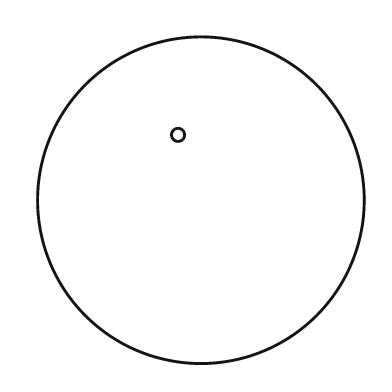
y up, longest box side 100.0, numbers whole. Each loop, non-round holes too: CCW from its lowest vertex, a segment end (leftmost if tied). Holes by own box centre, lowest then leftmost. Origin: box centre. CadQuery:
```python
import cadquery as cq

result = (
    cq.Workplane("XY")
    .moveTo(0.0, 0.0)
    .circle(50.0)
    .moveTo(-7.0, 20.0)
    .circle(2.0)
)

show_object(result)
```